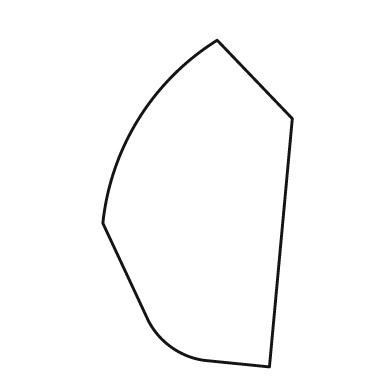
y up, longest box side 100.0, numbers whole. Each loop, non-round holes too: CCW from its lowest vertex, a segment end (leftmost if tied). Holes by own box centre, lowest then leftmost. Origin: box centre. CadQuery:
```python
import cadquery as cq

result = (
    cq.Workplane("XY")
    .moveTo(22.0, -50.0)
    .lineTo(29.0, 26.0)
    .lineTo(6.0, 50.0)
    .threePointArc((-18.0, 26.0), (-29.0, -6.0))
    .lineTo(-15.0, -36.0)
    .threePointArc((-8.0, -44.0), (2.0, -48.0))
    .close()
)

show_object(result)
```